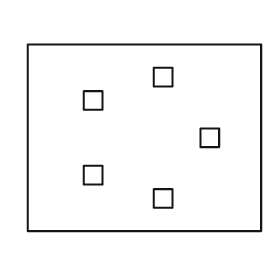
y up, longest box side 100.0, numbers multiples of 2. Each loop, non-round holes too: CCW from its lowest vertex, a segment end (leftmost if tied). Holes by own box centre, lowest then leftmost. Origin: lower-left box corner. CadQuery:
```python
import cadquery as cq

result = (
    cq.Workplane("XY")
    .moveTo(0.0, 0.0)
    .lineTo(100.0, 0.0)
    .lineTo(100.0, 80.0)
    .lineTo(0.0, 80.0)
    .close()
    .moveTo(54.0, 10.0)
    .lineTo(62.0, 10.0)
    .lineTo(62.0, 18.0)
    .lineTo(54.0, 18.0)
    .close()
    .moveTo(24.0, 20.0)
    .lineTo(32.0, 20.0)
    .lineTo(32.0, 28.0)
    .lineTo(24.0, 28.0)
    .close()
    .moveTo(74.0, 36.0)
    .lineTo(82.0, 36.0)
    .lineTo(82.0, 44.0)
    .lineTo(74.0, 44.0)
    .close()
    .moveTo(24.0, 52.0)
    .lineTo(32.0, 52.0)
    .lineTo(32.0, 60.0)
    .lineTo(24.0, 60.0)
    .close()
    .moveTo(54.0, 62.0)
    .lineTo(62.0, 62.0)
    .lineTo(62.0, 70.0)
    .lineTo(54.0, 70.0)
    .close()
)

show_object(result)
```